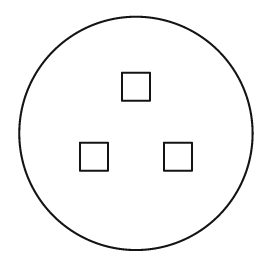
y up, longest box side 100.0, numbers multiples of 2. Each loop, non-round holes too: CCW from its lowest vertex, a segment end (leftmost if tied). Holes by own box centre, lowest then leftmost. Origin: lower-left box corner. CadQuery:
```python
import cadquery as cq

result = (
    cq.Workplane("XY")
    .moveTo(50.0, 50.0)
    .circle(50.0)
    .moveTo(26.0, 34.0)
    .lineTo(38.0, 34.0)
    .lineTo(38.0, 46.0)
    .lineTo(26.0, 46.0)
    .close()
    .moveTo(62.0, 34.0)
    .lineTo(74.0, 34.0)
    .lineTo(74.0, 46.0)
    .lineTo(62.0, 46.0)
    .close()
    .moveTo(44.0, 64.0)
    .lineTo(56.0, 64.0)
    .lineTo(56.0, 76.0)
    .lineTo(44.0, 76.0)
    .close()
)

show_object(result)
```